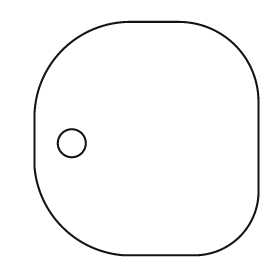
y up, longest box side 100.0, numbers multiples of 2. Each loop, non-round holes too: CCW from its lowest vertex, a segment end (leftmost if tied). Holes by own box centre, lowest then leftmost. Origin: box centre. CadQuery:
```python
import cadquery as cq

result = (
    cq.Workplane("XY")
    .moveTo(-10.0, -50.0)
    .lineTo(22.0, -50.0)
    .threePointArc((40.0, -42.0), (48.0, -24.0))
    .lineTo(48.0, 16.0)
    .threePointArc((38.0, 40.0), (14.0, 50.0))
    .lineTo(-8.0, 50.0)
    .threePointArc((-36.0, 38.0), (-48.0, 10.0))
    .lineTo(-48.0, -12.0)
    .threePointArc((-36.0, -38.0), (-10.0, -50.0))
    .close()
    .moveTo(-32.0, -2.0)
    .circle(6.0)
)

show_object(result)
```